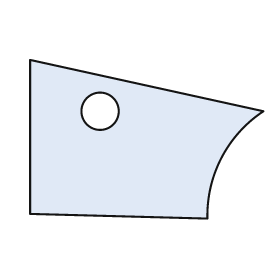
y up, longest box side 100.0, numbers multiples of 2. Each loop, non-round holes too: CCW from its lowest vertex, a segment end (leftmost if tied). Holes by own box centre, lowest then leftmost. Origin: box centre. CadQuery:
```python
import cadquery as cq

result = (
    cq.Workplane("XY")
    .moveTo(26.0, -34.0)
    .threePointArc((32.0, -8.0), (50.0, 12.0))
    .lineTo(-50.0, 34.0)
    .lineTo(-50.0, -32.0)
    .close()
    .moveTo(-20.0, 12.0)
    .circle(8.0)
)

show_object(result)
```